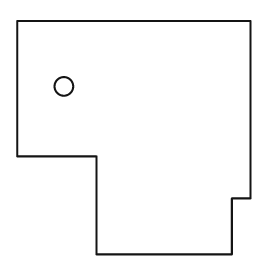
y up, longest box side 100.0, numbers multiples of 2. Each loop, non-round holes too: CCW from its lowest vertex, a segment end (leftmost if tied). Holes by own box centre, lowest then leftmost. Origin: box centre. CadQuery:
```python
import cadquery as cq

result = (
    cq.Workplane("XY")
    .moveTo(-16.0, -50.0)
    .lineTo(42.0, -50.0)
    .lineTo(42.0, -26.0)
    .lineTo(50.0, -26.0)
    .lineTo(50.0, 50.0)
    .lineTo(-50.0, 50.0)
    .lineTo(-50.0, -8.0)
    .lineTo(-16.0, -8.0)
    .close()
    .moveTo(-30.0, 22.0)
    .circle(4.0)
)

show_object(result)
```